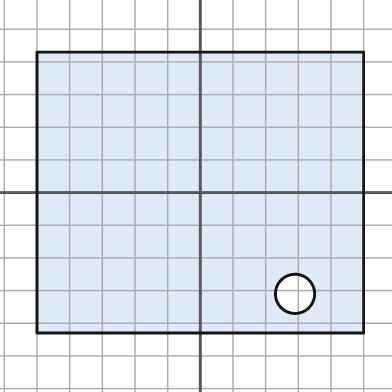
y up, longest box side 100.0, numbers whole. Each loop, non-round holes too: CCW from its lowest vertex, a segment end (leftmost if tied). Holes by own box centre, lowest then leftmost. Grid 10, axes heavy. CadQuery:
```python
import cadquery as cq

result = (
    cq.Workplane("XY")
    .moveTo(-50.0, -43.0)
    .lineTo(50.0, -43.0)
    .lineTo(50.0, 43.0)
    .lineTo(-50.0, 43.0)
    .close()
    .moveTo(29.0, -31.0)
    .circle(6.0)
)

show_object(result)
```